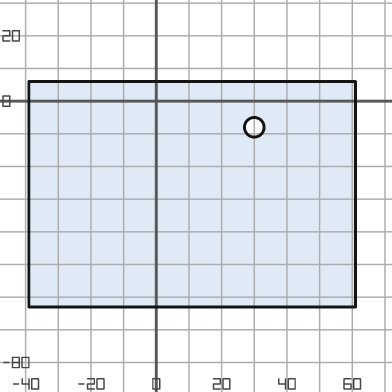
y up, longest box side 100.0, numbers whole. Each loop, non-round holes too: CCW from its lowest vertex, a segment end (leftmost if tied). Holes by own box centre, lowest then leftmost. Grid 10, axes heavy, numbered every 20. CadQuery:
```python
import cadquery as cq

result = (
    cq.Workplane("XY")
    .moveTo(-39.0, -63.0)
    .lineTo(61.0, -63.0)
    .lineTo(61.0, 6.0)
    .lineTo(-39.0, 6.0)
    .close()
    .moveTo(30.0, -8.0)
    .circle(3.0)
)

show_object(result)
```